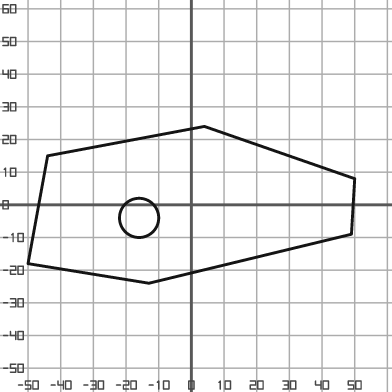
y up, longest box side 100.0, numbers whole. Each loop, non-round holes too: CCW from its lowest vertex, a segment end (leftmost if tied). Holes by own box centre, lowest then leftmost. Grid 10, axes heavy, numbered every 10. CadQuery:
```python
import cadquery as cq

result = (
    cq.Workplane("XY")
    .moveTo(-13.0, -24.0)
    .lineTo(49.0, -9.0)
    .lineTo(50.0, 8.0)
    .lineTo(4.0, 24.0)
    .lineTo(-44.0, 15.0)
    .lineTo(-50.0, -18.0)
    .close()
    .moveTo(-16.0, -4.0)
    .circle(6.0)
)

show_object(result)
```